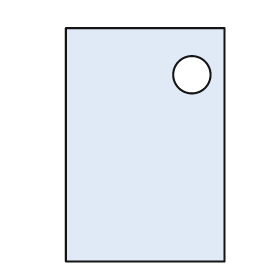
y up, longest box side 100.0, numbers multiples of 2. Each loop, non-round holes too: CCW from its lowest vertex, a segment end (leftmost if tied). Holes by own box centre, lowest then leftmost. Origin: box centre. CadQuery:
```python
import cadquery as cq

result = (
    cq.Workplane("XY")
    .moveTo(-34.0, -50.0)
    .lineTo(34.0, -50.0)
    .lineTo(34.0, 50.0)
    .lineTo(-34.0, 50.0)
    .close()
    .moveTo(20.0, 30.0)
    .circle(8.0)
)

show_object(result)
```